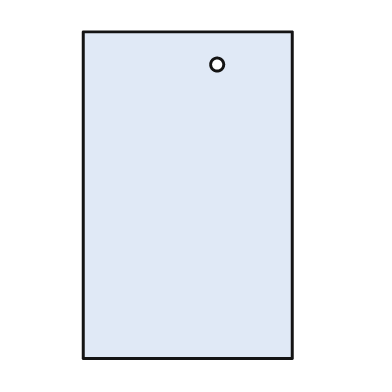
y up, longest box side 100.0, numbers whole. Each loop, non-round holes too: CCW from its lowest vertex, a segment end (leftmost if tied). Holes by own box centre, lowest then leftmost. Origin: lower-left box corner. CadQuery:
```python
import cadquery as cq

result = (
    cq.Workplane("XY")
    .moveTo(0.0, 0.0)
    .lineTo(64.0, 0.0)
    .lineTo(64.0, 100.0)
    .lineTo(0.0, 100.0)
    .close()
    .moveTo(41.0, 90.0)
    .circle(2.0)
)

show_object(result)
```